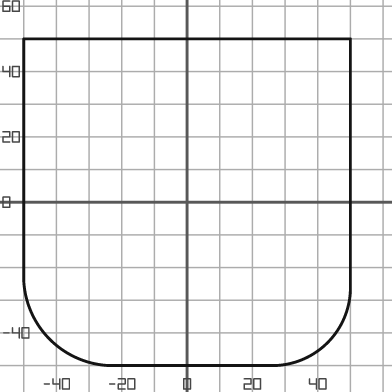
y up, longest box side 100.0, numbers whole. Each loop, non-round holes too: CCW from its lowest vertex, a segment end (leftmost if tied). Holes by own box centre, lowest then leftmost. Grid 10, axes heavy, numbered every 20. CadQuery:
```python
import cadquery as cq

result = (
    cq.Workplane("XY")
    .moveTo(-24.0, -50.0)
    .lineTo(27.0, -50.0)
    .threePointArc((43.0, -43.0), (50.0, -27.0))
    .lineTo(50.0, 50.0)
    .lineTo(-50.0, 50.0)
    .lineTo(-50.0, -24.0)
    .threePointArc((-42.0, -42.0), (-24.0, -50.0))
    .close()
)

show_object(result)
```